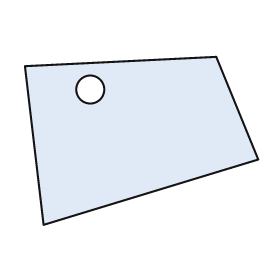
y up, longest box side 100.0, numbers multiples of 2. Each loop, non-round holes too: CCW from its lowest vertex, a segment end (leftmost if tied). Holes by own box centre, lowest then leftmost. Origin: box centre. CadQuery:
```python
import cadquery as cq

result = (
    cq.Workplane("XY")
    .moveTo(-42.0, -36.0)
    .lineTo(50.0, -8.0)
    .lineTo(32.0, 36.0)
    .lineTo(-50.0, 32.0)
    .close()
    .moveTo(-22.0, 22.0)
    .circle(6.0)
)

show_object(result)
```